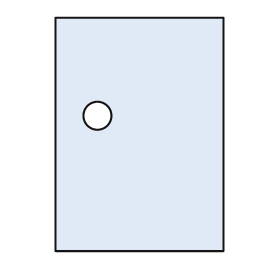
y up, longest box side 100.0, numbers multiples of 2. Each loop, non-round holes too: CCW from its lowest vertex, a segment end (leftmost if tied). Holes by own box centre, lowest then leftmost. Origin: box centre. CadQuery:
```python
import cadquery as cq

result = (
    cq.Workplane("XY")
    .moveTo(-36.0, -50.0)
    .lineTo(36.0, -50.0)
    .lineTo(36.0, 50.0)
    .lineTo(-36.0, 50.0)
    .close()
    .moveTo(-18.0, 8.0)
    .circle(6.0)
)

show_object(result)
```